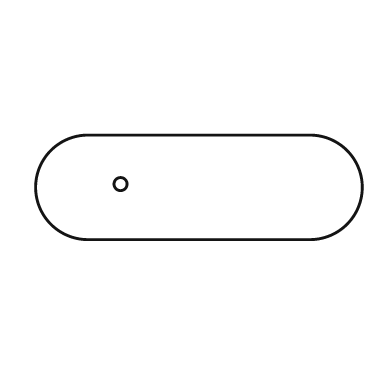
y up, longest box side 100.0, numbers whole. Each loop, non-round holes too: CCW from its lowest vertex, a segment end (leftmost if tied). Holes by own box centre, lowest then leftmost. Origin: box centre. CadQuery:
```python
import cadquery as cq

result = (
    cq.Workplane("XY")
    .moveTo(-34.0, -16.0)
    .lineTo(34.0, -16.0)
    .threePointArc((50.0, 0.0), (34.0, 16.0))
    .lineTo(-34.0, 16.0)
    .threePointArc((-50.0, 0.0), (-34.0, -16.0))
    .close()
    .moveTo(-24.0, 1.0)
    .circle(2.0)
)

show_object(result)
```